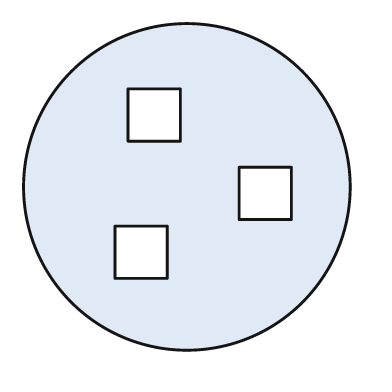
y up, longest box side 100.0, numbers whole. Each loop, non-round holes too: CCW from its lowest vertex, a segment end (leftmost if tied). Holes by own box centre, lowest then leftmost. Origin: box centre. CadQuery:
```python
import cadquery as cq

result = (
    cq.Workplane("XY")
    .moveTo(0.0, 0.0)
    .circle(50.0)
    .moveTo(-22.0, -28.0)
    .lineTo(-6.0, -28.0)
    .lineTo(-6.0, -12.0)
    .lineTo(-22.0, -12.0)
    .close()
    .moveTo(16.0, -10.0)
    .lineTo(32.0, -10.0)
    .lineTo(32.0, 6.0)
    .lineTo(16.0, 6.0)
    .close()
    .moveTo(-18.0, 14.0)
    .lineTo(-2.0, 14.0)
    .lineTo(-2.0, 30.0)
    .lineTo(-18.0, 30.0)
    .close()
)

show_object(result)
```